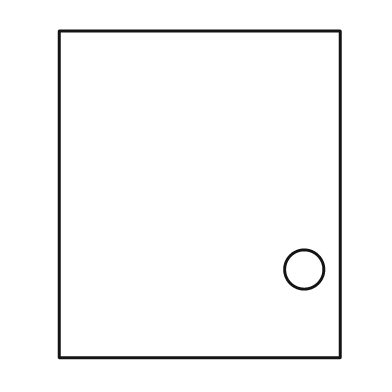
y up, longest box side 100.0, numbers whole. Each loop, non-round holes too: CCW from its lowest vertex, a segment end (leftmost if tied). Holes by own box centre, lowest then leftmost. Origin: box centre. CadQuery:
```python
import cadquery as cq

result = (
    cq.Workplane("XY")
    .moveTo(-43.0, -50.0)
    .lineTo(43.0, -50.0)
    .lineTo(43.0, 50.0)
    .lineTo(-43.0, 50.0)
    .close()
    .moveTo(32.0, -23.0)
    .circle(6.0)
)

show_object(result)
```